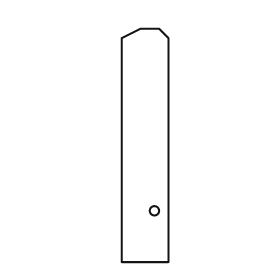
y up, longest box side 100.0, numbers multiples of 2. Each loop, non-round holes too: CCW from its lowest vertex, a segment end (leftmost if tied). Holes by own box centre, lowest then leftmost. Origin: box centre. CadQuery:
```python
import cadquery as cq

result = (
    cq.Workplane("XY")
    .moveTo(-10.0, -50.0)
    .lineTo(10.0, -50.0)
    .lineTo(10.0, 46.0)
    .lineTo(6.0, 50.0)
    .lineTo(-2.0, 50.0)
    .lineTo(-10.0, 46.0)
    .close()
    .moveTo(4.0, -28.0)
    .circle(2.0)
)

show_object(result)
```